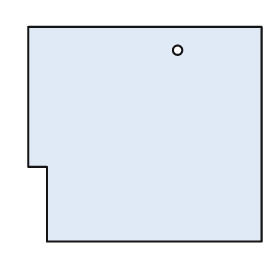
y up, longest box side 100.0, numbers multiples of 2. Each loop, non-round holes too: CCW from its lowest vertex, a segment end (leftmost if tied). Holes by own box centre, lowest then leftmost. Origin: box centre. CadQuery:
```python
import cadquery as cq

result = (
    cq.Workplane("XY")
    .moveTo(-42.0, -46.0)
    .lineTo(50.0, -46.0)
    .lineTo(50.0, 46.0)
    .lineTo(-50.0, 46.0)
    .lineTo(-50.0, -14.0)
    .lineTo(-42.0, -14.0)
    .close()
    .moveTo(14.0, 36.0)
    .circle(2.0)
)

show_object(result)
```